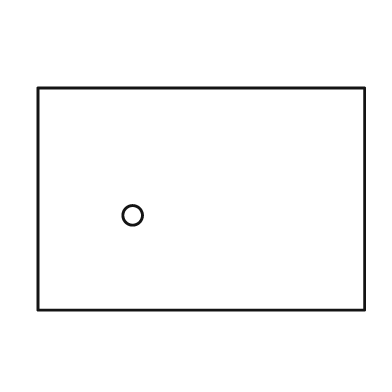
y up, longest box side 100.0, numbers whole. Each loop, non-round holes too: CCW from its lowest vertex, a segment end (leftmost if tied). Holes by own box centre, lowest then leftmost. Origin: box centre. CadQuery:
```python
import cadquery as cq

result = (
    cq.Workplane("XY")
    .moveTo(-50.0, -34.0)
    .lineTo(50.0, -34.0)
    .lineTo(50.0, 34.0)
    .lineTo(-50.0, 34.0)
    .close()
    .moveTo(-21.0, -5.0)
    .circle(3.0)
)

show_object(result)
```